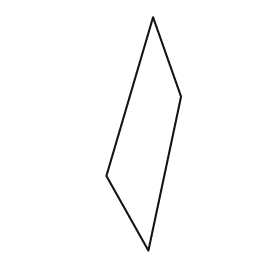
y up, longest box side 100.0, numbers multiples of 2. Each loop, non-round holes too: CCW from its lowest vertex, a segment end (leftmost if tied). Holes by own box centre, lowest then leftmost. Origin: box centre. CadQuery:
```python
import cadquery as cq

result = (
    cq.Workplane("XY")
    .moveTo(2.0, -50.0)
    .lineTo(16.0, 16.0)
    .lineTo(4.0, 50.0)
    .lineTo(-16.0, -18.0)
    .close()
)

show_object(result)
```